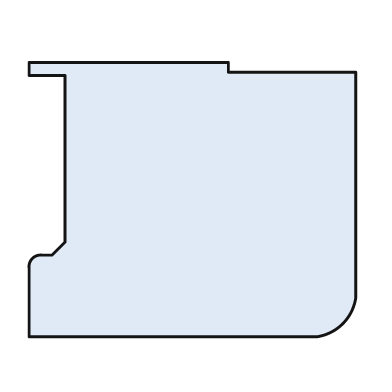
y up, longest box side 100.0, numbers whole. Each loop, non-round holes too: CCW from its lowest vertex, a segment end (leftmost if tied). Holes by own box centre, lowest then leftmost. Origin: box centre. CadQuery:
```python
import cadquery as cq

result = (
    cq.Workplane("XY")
    .moveTo(-50.0, -42.0)
    .lineTo(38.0, -42.0)
    .threePointArc((46.0, -38.0), (50.0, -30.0))
    .lineTo(50.0, 39.0)
    .lineTo(11.0, 39.0)
    .lineTo(11.0, 42.0)
    .lineTo(-50.0, 42.0)
    .lineTo(-50.0, 38.0)
    .lineTo(-39.0, 38.0)
    .lineTo(-39.0, -13.0)
    .lineTo(-43.0, -17.0)
    .lineTo(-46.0, -17.0)
    .threePointArc((-49.0, -18.0), (-50.0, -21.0))
    .close()
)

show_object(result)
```